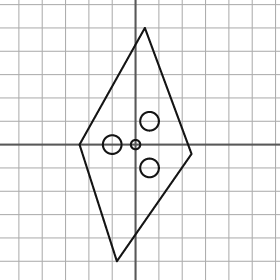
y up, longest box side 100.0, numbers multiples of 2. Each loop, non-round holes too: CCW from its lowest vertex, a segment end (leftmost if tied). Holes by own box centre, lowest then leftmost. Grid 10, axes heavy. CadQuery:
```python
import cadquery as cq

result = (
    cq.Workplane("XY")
    .moveTo(-8.0, -50.0)
    .lineTo(24.0, -4.0)
    .lineTo(4.0, 50.0)
    .lineTo(-24.0, 0.0)
    .close()
    .moveTo(6.0, -10.0)
    .circle(4.0)
    .moveTo(-10.0, 0.0)
    .circle(4.0)
    .moveTo(0.0, 0.0)
    .circle(2.0)
    .moveTo(6.0, 10.0)
    .circle(4.0)
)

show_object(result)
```